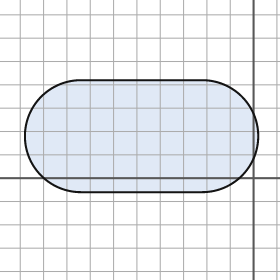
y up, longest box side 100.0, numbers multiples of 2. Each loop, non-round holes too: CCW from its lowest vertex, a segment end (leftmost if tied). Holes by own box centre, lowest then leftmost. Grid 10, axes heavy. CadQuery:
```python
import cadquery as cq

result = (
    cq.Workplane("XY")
    .moveTo(-74.0, -6.0)
    .lineTo(-22.0, -6.0)
    .threePointArc((2.0, 18.0), (-22.0, 42.0))
    .lineTo(-74.0, 42.0)
    .threePointArc((-98.0, 18.0), (-74.0, -6.0))
    .close()
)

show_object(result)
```